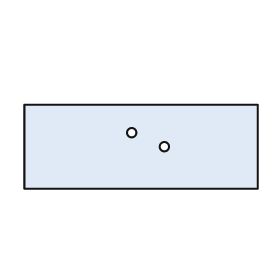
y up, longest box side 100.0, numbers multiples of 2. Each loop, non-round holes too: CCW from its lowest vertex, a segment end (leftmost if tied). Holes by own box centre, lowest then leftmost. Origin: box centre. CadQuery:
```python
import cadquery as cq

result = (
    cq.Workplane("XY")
    .moveTo(-50.0, -18.0)
    .lineTo(50.0, -18.0)
    .lineTo(50.0, 18.0)
    .lineTo(-50.0, 18.0)
    .close()
    .moveTo(10.0, 0.0)
    .circle(2.0)
    .moveTo(-4.0, 6.0)
    .circle(2.0)
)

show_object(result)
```